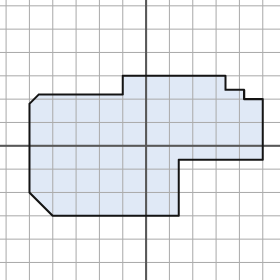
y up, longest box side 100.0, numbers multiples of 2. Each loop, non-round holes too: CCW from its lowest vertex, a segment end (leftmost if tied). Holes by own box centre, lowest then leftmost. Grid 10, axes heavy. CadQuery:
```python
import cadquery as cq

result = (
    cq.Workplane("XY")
    .moveTo(-40.0, -30.0)
    .lineTo(14.0, -30.0)
    .lineTo(14.0, -6.0)
    .lineTo(50.0, -6.0)
    .lineTo(50.0, 20.0)
    .lineTo(42.0, 20.0)
    .lineTo(42.0, 24.0)
    .lineTo(34.0, 24.0)
    .lineTo(34.0, 30.0)
    .lineTo(-10.0, 30.0)
    .lineTo(-10.0, 22.0)
    .lineTo(-46.0, 22.0)
    .lineTo(-50.0, 18.0)
    .lineTo(-50.0, -20.0)
    .close()
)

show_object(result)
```